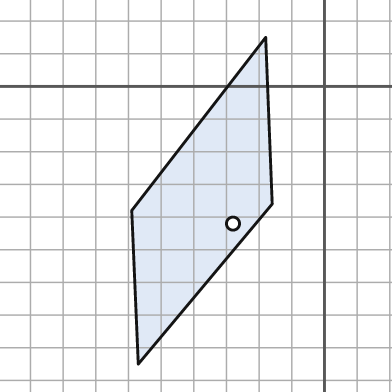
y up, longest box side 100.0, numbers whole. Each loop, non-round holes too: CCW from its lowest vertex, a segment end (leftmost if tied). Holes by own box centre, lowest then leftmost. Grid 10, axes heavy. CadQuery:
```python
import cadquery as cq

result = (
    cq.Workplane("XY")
    .moveTo(-57.0, -85.0)
    .lineTo(-16.0, -36.0)
    .lineTo(-18.0, 15.0)
    .lineTo(-59.0, -38.0)
    .close()
    .moveTo(-28.0, -42.0)
    .circle(2.0)
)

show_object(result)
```